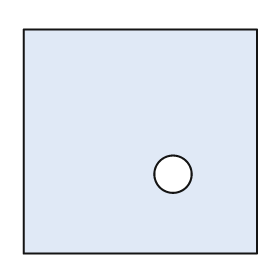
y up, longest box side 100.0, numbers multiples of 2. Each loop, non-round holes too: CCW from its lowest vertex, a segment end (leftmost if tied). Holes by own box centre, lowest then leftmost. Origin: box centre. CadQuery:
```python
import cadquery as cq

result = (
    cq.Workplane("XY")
    .moveTo(-50.0, -48.0)
    .lineTo(50.0, -48.0)
    .lineTo(50.0, 48.0)
    .lineTo(-50.0, 48.0)
    .close()
    .moveTo(14.0, -14.0)
    .circle(8.0)
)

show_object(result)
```